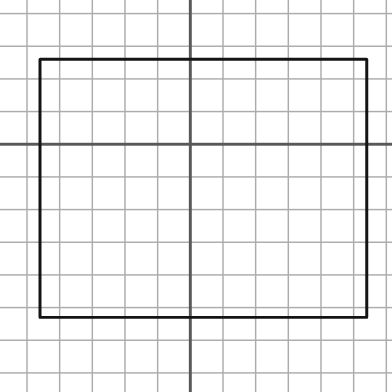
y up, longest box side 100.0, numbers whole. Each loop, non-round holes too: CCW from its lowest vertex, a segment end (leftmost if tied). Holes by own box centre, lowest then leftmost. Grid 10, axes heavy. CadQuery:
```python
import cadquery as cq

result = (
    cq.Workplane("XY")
    .moveTo(-46.0, -53.0)
    .lineTo(54.0, -53.0)
    .lineTo(54.0, 26.0)
    .lineTo(-46.0, 26.0)
    .close()
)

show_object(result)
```